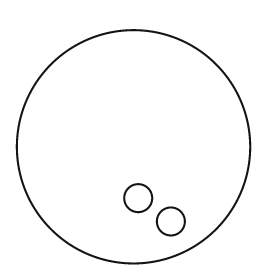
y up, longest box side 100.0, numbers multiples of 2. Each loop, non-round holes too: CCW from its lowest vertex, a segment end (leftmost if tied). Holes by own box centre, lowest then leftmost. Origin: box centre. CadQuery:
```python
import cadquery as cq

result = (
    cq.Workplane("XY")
    .moveTo(0.0, 0.0)
    .circle(50.0)
    .moveTo(16.0, -32.0)
    .circle(6.0)
    .moveTo(2.0, -22.0)
    .circle(6.0)
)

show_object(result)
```